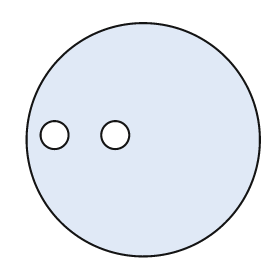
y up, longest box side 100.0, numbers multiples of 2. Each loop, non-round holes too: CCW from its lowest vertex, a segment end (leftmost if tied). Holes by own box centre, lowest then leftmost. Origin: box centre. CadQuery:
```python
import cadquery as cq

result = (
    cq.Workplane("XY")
    .moveTo(0.0, 0.0)
    .circle(50.0)
    .moveTo(-38.0, 2.0)
    .circle(6.0)
    .moveTo(-12.0, 2.0)
    .circle(6.0)
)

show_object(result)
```